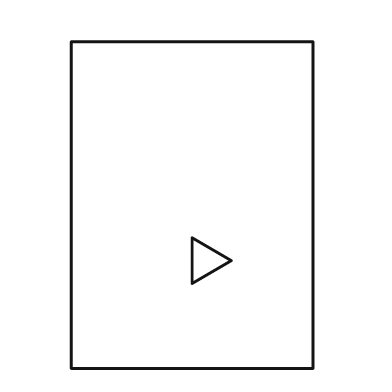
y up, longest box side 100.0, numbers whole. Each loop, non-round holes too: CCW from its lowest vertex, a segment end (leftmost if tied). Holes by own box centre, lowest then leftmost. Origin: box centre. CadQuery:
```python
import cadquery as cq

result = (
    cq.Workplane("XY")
    .moveTo(-37.0, -50.0)
    .lineTo(37.0, -50.0)
    .lineTo(37.0, 50.0)
    .lineTo(-37.0, 50.0)
    .close()
    .moveTo(0.0, -24.0)
    .lineTo(12.0, -17.0)
    .lineTo(0.0, -10.0)
    .close()
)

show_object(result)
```